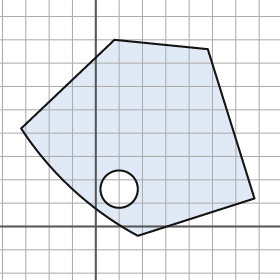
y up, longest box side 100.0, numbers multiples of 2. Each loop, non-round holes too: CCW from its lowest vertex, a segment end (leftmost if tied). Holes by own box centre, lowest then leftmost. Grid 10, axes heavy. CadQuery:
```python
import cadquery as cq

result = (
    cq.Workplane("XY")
    .moveTo(18.0, -4.0)
    .lineTo(68.0, 12.0)
    .lineTo(48.0, 76.0)
    .lineTo(8.0, 80.0)
    .lineTo(-32.0, 42.0)
    .threePointArc((-10.0, 16.0), (18.0, -4.0))
    .close()
    .moveTo(10.0, 16.0)
    .circle(8.0)
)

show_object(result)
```